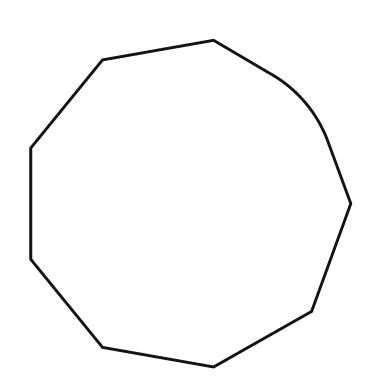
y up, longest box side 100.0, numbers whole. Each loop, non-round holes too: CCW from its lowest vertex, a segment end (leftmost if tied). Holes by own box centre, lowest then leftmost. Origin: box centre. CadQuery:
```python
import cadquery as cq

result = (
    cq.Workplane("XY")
    .moveTo(7.0, -50.0)
    .lineTo(37.0, -33.0)
    .lineTo(49.0, 0.0)
    .lineTo(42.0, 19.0)
    .threePointArc((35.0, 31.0), (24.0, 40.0))
    .lineTo(7.0, 50.0)
    .lineTo(-27.0, 44.0)
    .lineTo(-49.0, 17.0)
    .lineTo(-49.0, -17.0)
    .lineTo(-27.0, -44.0)
    .close()
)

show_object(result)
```